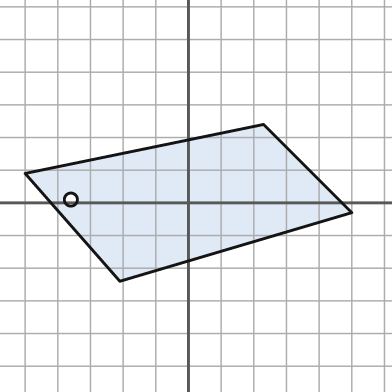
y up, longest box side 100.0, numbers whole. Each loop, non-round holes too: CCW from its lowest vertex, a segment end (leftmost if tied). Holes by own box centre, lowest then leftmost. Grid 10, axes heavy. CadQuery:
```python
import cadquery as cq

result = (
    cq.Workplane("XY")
    .moveTo(-21.0, -24.0)
    .lineTo(50.0, -3.0)
    .lineTo(23.0, 24.0)
    .lineTo(-50.0, 9.0)
    .close()
    .moveTo(-36.0, 1.0)
    .circle(2.0)
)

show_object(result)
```